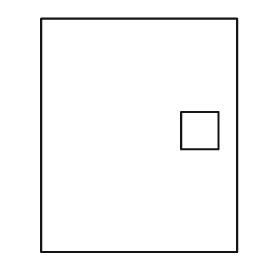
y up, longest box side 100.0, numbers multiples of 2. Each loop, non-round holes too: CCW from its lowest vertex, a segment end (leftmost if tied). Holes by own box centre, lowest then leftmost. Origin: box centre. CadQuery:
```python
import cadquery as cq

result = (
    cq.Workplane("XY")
    .moveTo(-42.0, -50.0)
    .lineTo(42.0, -50.0)
    .lineTo(42.0, 50.0)
    .lineTo(-42.0, 50.0)
    .close()
    .moveTo(18.0, -6.0)
    .lineTo(34.0, -6.0)
    .lineTo(34.0, 10.0)
    .lineTo(18.0, 10.0)
    .close()
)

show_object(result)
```